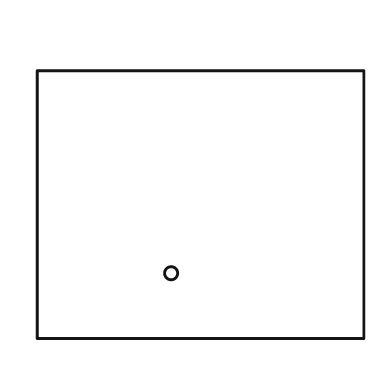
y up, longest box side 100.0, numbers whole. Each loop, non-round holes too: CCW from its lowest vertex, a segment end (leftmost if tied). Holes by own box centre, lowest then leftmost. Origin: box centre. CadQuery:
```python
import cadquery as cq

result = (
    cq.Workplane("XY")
    .moveTo(-50.0, -41.0)
    .lineTo(50.0, -41.0)
    .lineTo(50.0, 41.0)
    .lineTo(-50.0, 41.0)
    .close()
    .moveTo(-9.0, -21.0)
    .circle(2.0)
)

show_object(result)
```